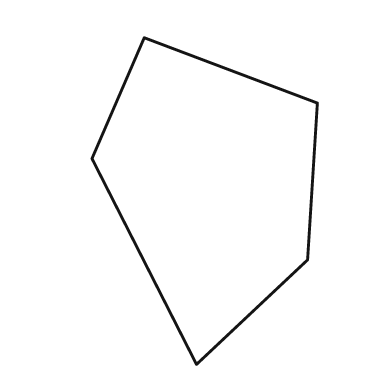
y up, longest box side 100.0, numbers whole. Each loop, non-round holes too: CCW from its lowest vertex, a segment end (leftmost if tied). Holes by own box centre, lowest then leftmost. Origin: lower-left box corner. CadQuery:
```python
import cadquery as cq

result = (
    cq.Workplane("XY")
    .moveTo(32.0, 0.0)
    .lineTo(66.0, 32.0)
    .lineTo(69.0, 80.0)
    .lineTo(16.0, 100.0)
    .lineTo(0.0, 63.0)
    .close()
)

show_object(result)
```